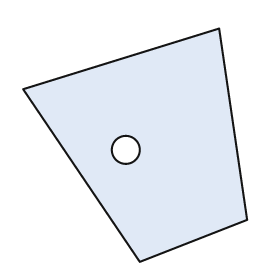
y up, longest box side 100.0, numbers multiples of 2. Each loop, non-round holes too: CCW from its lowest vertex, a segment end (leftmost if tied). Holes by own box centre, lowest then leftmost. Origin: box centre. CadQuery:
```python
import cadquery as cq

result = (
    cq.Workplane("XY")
    .moveTo(2.0, -50.0)
    .lineTo(48.0, -32.0)
    .lineTo(36.0, 50.0)
    .lineTo(-48.0, 24.0)
    .close()
    .moveTo(-4.0, -2.0)
    .circle(6.0)
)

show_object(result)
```